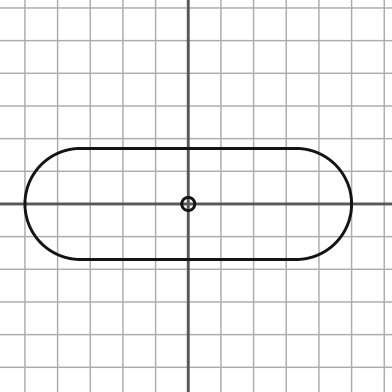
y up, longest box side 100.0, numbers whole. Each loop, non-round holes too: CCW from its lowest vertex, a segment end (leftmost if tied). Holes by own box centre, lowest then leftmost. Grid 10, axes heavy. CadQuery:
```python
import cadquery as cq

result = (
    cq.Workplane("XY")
    .moveTo(-33.0, -17.0)
    .lineTo(33.0, -17.0)
    .threePointArc((50.0, 0.0), (33.0, 17.0))
    .lineTo(-33.0, 17.0)
    .threePointArc((-50.0, 0.0), (-33.0, -17.0))
    .close()
    .moveTo(0.0, 0.0)
    .circle(2.0)
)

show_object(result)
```